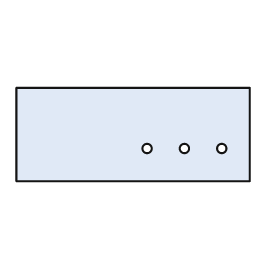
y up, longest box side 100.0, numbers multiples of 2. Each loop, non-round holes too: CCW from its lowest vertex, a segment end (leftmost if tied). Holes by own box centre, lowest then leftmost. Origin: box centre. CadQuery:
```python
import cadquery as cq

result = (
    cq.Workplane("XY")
    .moveTo(-50.0, -20.0)
    .lineTo(50.0, -20.0)
    .lineTo(50.0, 20.0)
    .lineTo(-50.0, 20.0)
    .close()
    .moveTo(6.0, -6.0)
    .circle(2.0)
    .moveTo(22.0, -6.0)
    .circle(2.0)
    .moveTo(38.0, -6.0)
    .circle(2.0)
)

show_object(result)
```